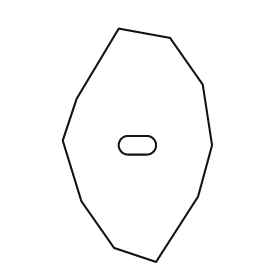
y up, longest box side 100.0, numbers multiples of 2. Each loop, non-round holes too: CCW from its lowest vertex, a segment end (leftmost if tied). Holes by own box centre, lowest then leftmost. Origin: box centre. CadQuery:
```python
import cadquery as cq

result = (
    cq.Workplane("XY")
    .moveTo(8.0, -50.0)
    .lineTo(26.0, -22.0)
    .lineTo(32.0, 0.0)
    .lineTo(28.0, 26.0)
    .lineTo(14.0, 46.0)
    .lineTo(-8.0, 50.0)
    .lineTo(-26.0, 20.0)
    .lineTo(-32.0, 2.0)
    .lineTo(-24.0, -24.0)
    .lineTo(-10.0, -44.0)
    .close()
    .moveTo(-4.0, -4.0)
    .lineTo(4.0, -4.0)
    .threePointArc((8.0, 0.0), (4.0, 4.0))
    .lineTo(-4.0, 4.0)
    .threePointArc((-8.0, 0.0), (-4.0, -4.0))
    .close()
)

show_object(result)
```